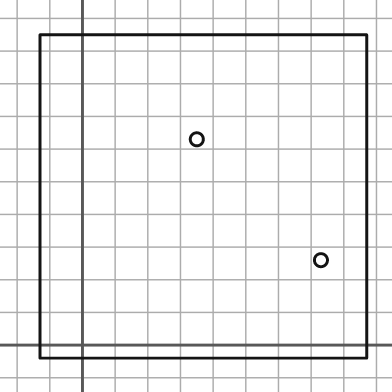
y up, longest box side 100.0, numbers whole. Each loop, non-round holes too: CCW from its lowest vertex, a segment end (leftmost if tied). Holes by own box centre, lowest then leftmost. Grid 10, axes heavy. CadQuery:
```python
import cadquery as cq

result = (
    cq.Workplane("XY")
    .moveTo(-13.0, -4.0)
    .lineTo(87.0, -4.0)
    .lineTo(87.0, 95.0)
    .lineTo(-13.0, 95.0)
    .close()
    .moveTo(73.0, 26.0)
    .circle(2.0)
    .moveTo(35.0, 63.0)
    .circle(2.0)
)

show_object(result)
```